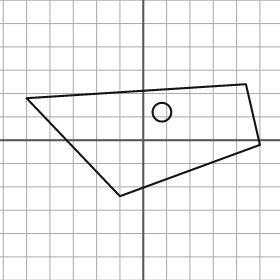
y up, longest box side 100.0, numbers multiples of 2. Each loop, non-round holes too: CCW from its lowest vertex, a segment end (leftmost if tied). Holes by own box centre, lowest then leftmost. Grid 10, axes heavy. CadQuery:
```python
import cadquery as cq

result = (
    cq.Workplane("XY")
    .moveTo(-10.0, -24.0)
    .lineTo(50.0, -2.0)
    .lineTo(44.0, 24.0)
    .lineTo(-50.0, 18.0)
    .close()
    .moveTo(8.0, 12.0)
    .circle(4.0)
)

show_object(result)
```